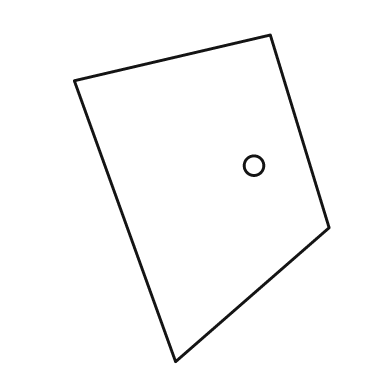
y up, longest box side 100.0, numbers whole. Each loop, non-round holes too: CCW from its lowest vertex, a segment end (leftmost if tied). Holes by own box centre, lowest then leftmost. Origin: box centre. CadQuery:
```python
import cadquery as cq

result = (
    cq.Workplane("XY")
    .moveTo(-8.0, -50.0)
    .lineTo(39.0, -9.0)
    .lineTo(21.0, 50.0)
    .lineTo(-39.0, 36.0)
    .close()
    .moveTo(16.0, 10.0)
    .circle(3.0)
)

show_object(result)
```